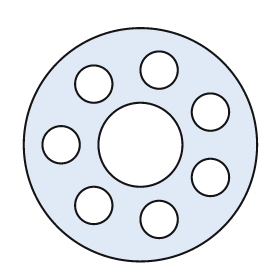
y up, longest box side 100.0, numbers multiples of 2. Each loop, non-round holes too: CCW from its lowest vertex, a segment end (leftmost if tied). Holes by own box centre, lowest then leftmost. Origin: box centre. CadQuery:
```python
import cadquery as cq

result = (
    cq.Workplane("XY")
    .moveTo(0.0, 0.0)
    .circle(50.0)
    .moveTo(8.0, -32.0)
    .circle(8.0)
    .moveTo(-20.0, -26.0)
    .circle(8.0)
    .moveTo(30.0, -14.0)
    .circle(8.0)
    .moveTo(-34.0, 0.0)
    .circle(8.0)
    .moveTo(0.0, 0.0)
    .circle(18.0)
    .moveTo(30.0, 14.0)
    .circle(8.0)
    .moveTo(-20.0, 26.0)
    .circle(8.0)
    .moveTo(8.0, 32.0)
    .circle(8.0)
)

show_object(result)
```